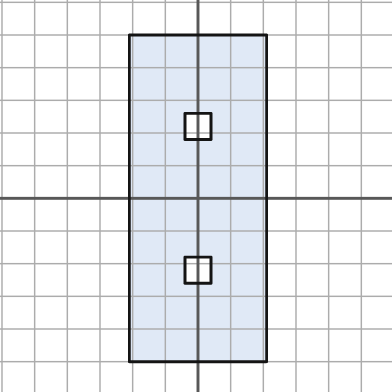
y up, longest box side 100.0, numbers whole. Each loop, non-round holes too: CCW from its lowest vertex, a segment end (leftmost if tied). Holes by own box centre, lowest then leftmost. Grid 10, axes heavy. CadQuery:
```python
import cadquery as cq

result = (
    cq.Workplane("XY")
    .moveTo(-21.0, -50.0)
    .lineTo(21.0, -50.0)
    .lineTo(21.0, 50.0)
    .lineTo(-21.0, 50.0)
    .close()
    .moveTo(-4.0, -26.0)
    .lineTo(4.0, -26.0)
    .lineTo(4.0, -18.0)
    .lineTo(-4.0, -18.0)
    .close()
    .moveTo(-4.0, 18.0)
    .lineTo(4.0, 18.0)
    .lineTo(4.0, 26.0)
    .lineTo(-4.0, 26.0)
    .close()
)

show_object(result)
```